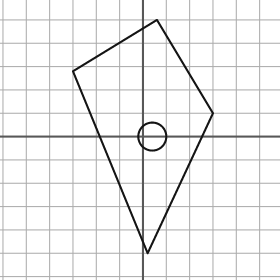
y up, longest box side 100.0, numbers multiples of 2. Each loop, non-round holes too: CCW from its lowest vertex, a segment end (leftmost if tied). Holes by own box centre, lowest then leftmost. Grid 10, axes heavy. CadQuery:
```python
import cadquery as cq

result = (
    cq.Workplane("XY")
    .moveTo(2.0, -50.0)
    .lineTo(30.0, 10.0)
    .lineTo(6.0, 50.0)
    .lineTo(-30.0, 28.0)
    .close()
    .moveTo(4.0, 0.0)
    .circle(6.0)
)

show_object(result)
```